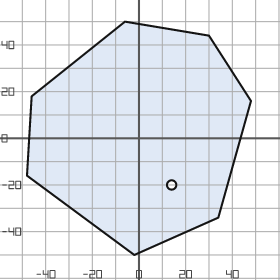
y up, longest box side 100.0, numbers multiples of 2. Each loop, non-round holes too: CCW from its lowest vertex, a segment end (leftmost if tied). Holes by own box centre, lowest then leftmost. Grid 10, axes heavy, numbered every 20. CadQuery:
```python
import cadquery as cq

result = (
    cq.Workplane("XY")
    .moveTo(-2.0, -50.0)
    .lineTo(34.0, -34.0)
    .lineTo(48.0, 16.0)
    .lineTo(30.0, 44.0)
    .lineTo(-6.0, 50.0)
    .lineTo(-46.0, 18.0)
    .lineTo(-48.0, -16.0)
    .close()
    .moveTo(14.0, -20.0)
    .circle(2.0)
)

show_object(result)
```